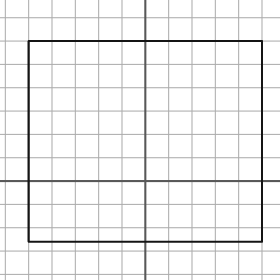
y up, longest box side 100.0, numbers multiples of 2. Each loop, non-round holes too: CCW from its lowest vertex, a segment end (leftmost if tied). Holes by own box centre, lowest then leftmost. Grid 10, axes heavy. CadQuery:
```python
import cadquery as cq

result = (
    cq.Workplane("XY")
    .moveTo(-50.0, -26.0)
    .lineTo(50.0, -26.0)
    .lineTo(50.0, 60.0)
    .lineTo(-50.0, 60.0)
    .close()
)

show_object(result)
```